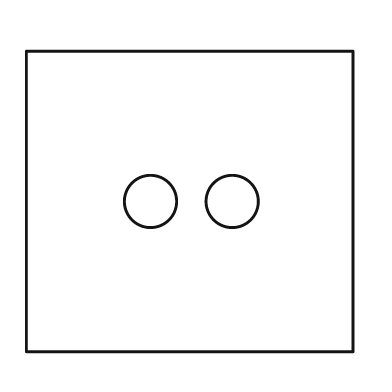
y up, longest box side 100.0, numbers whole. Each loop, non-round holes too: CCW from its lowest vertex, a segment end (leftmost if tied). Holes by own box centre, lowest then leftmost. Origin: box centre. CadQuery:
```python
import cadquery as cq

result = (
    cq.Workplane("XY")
    .moveTo(-50.0, -46.0)
    .lineTo(50.0, -46.0)
    .lineTo(50.0, 46.0)
    .lineTo(-50.0, 46.0)
    .close()
    .moveTo(-12.0, 0.0)
    .circle(8.0)
    .moveTo(13.0, 0.0)
    .circle(8.0)
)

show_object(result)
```